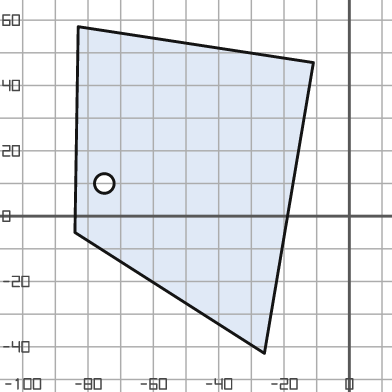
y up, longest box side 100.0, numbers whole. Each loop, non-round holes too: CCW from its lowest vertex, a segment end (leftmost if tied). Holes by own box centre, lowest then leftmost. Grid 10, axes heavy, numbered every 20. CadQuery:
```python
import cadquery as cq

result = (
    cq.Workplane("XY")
    .moveTo(-26.0, -42.0)
    .lineTo(-11.0, 47.0)
    .lineTo(-83.0, 58.0)
    .lineTo(-84.0, -5.0)
    .close()
    .moveTo(-75.0, 10.0)
    .circle(3.0)
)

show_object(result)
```